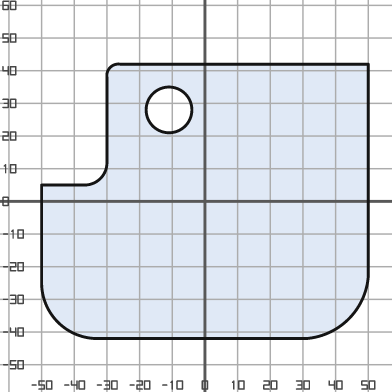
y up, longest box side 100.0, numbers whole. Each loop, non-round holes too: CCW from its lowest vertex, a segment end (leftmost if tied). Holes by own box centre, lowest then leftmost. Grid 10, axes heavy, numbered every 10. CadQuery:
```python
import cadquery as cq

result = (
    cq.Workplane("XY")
    .moveTo(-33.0, -42.0)
    .lineTo(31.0, -42.0)
    .threePointArc((44.0, -36.0), (50.0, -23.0))
    .lineTo(50.0, 42.0)
    .lineTo(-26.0, 42.0)
    .threePointArc((-29.0, 41.0), (-30.0, 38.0))
    .lineTo(-30.0, 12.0)
    .threePointArc((-32.0, 7.0), (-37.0, 5.0))
    .lineTo(-50.0, 5.0)
    .lineTo(-50.0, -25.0)
    .threePointArc((-45.0, -37.0), (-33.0, -42.0))
    .close()
    .moveTo(-11.0, 28.0)
    .circle(7.0)
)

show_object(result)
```